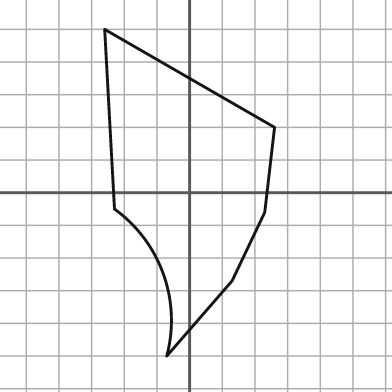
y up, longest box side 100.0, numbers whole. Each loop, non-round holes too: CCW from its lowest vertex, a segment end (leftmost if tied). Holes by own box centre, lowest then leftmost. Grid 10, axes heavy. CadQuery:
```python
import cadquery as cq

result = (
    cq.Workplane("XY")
    .moveTo(-7.0, -50.0)
    .lineTo(13.0, -27.0)
    .lineTo(23.0, -6.0)
    .lineTo(26.0, 20.0)
    .lineTo(-26.0, 50.0)
    .lineTo(-23.0, -5.0)
    .threePointArc((-8.0, -25.0), (-7.0, -50.0))
    .close()
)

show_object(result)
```